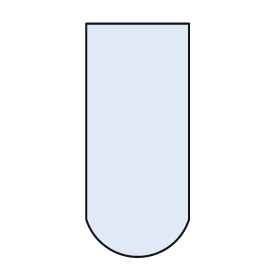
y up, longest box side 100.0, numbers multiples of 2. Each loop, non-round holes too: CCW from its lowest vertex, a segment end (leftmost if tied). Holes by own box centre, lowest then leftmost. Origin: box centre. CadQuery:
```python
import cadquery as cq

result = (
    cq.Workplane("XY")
    .moveTo(-22.0, -34.0)
    .threePointArc((0.0, -50.0), (22.0, -34.0))
    .lineTo(22.0, 50.0)
    .lineTo(-22.0, 50.0)
    .close()
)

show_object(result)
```